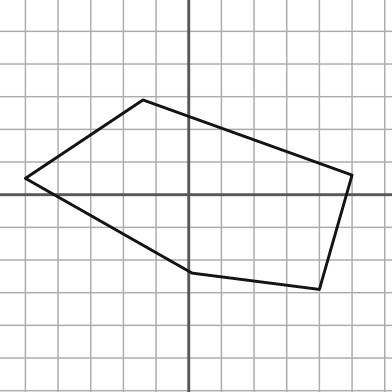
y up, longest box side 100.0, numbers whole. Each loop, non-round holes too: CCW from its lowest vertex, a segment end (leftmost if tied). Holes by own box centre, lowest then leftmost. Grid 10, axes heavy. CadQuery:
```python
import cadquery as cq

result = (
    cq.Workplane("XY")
    .moveTo(40.0, -29.0)
    .lineTo(50.0, 6.0)
    .lineTo(-14.0, 29.0)
    .lineTo(-50.0, 5.0)
    .lineTo(1.0, -24.0)
    .close()
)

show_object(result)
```